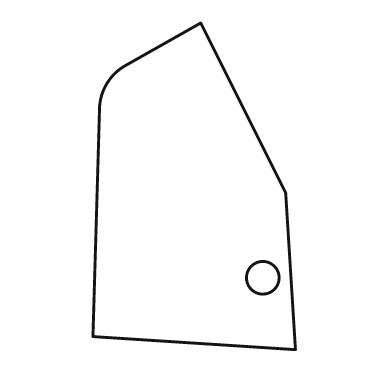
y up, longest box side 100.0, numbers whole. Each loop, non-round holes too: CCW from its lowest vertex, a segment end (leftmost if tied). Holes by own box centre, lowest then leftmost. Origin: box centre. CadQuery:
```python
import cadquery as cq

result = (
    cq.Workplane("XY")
    .moveTo(31.0, -50.0)
    .lineTo(28.0, -2.0)
    .lineTo(2.0, 50.0)
    .lineTo(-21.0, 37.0)
    .threePointArc((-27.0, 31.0), (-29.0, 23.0))
    .lineTo(-31.0, -46.0)
    .close()
    .moveTo(21.0, -28.0)
    .circle(5.0)
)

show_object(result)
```